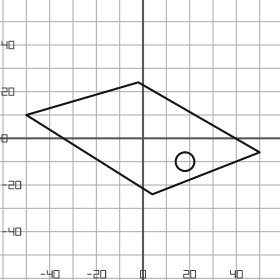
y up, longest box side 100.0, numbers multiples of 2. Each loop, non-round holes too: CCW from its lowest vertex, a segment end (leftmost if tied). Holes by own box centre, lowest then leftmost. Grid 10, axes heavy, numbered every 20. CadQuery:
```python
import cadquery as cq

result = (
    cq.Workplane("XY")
    .moveTo(4.0, -24.0)
    .lineTo(50.0, -6.0)
    .lineTo(-2.0, 24.0)
    .lineTo(-50.0, 10.0)
    .close()
    .moveTo(18.0, -10.0)
    .circle(4.0)
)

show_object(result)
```